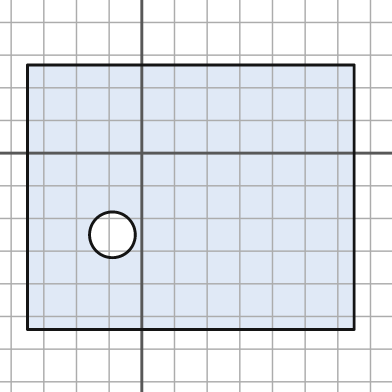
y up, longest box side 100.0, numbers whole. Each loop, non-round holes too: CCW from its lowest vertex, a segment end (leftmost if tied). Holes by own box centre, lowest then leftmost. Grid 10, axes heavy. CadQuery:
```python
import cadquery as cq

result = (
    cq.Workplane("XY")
    .moveTo(-35.0, -54.0)
    .lineTo(65.0, -54.0)
    .lineTo(65.0, 27.0)
    .lineTo(-35.0, 27.0)
    .close()
    .moveTo(-9.0, -25.0)
    .circle(7.0)
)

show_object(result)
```